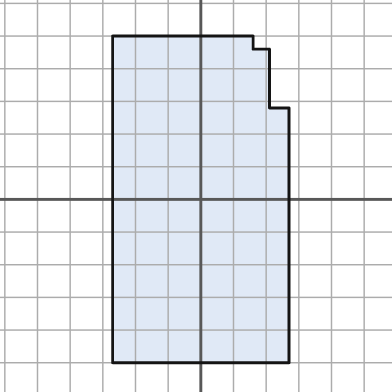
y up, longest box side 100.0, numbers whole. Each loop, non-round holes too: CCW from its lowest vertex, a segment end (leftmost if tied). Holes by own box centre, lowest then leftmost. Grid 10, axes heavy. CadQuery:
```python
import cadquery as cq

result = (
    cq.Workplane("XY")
    .moveTo(-27.0, -50.0)
    .lineTo(27.0, -50.0)
    .lineTo(27.0, 28.0)
    .lineTo(21.0, 28.0)
    .lineTo(21.0, 46.0)
    .lineTo(16.0, 46.0)
    .lineTo(16.0, 50.0)
    .lineTo(-27.0, 50.0)
    .close()
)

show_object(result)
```